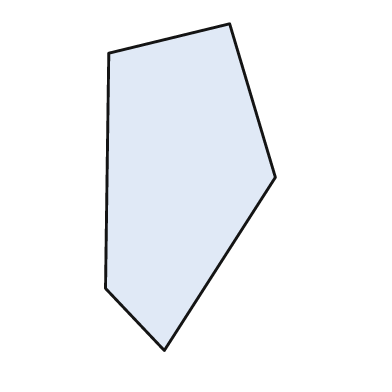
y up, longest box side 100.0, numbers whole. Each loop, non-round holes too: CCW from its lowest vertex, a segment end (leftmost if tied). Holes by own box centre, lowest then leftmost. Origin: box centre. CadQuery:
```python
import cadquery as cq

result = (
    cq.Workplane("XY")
    .moveTo(-8.0, -50.0)
    .lineTo(26.0, 3.0)
    .lineTo(12.0, 50.0)
    .lineTo(-25.0, 41.0)
    .lineTo(-26.0, -31.0)
    .close()
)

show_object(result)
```